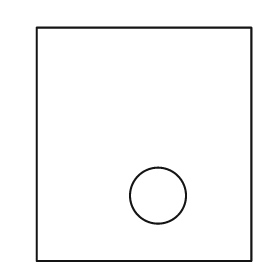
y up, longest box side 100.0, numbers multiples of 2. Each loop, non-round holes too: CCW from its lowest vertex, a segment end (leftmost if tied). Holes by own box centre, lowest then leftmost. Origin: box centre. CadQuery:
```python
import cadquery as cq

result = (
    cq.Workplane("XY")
    .moveTo(-46.0, -50.0)
    .lineTo(46.0, -50.0)
    .lineTo(46.0, 50.0)
    .lineTo(-46.0, 50.0)
    .close()
    .moveTo(6.0, -22.0)
    .circle(12.0)
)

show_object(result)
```